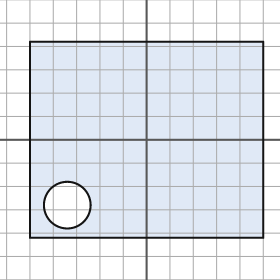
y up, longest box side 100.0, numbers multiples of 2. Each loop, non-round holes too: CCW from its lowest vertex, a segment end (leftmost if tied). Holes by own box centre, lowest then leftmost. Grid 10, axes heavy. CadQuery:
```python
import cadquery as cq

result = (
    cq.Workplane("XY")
    .moveTo(-50.0, -42.0)
    .lineTo(50.0, -42.0)
    .lineTo(50.0, 42.0)
    .lineTo(-50.0, 42.0)
    .close()
    .moveTo(-34.0, -28.0)
    .circle(10.0)
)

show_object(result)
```